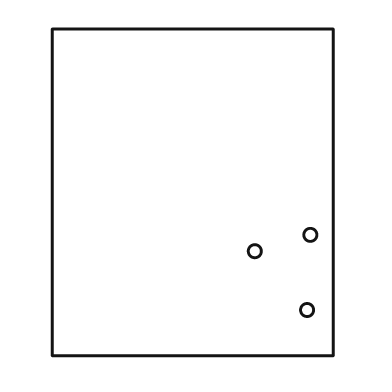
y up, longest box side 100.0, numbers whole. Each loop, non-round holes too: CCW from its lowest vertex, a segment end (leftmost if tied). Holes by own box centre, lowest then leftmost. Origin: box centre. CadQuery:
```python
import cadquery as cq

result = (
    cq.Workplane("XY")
    .moveTo(-43.0, -50.0)
    .lineTo(43.0, -50.0)
    .lineTo(43.0, 50.0)
    .lineTo(-43.0, 50.0)
    .close()
    .moveTo(35.0, -36.0)
    .circle(2.0)
    .moveTo(19.0, -18.0)
    .circle(2.0)
    .moveTo(36.0, -13.0)
    .circle(2.0)
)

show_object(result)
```